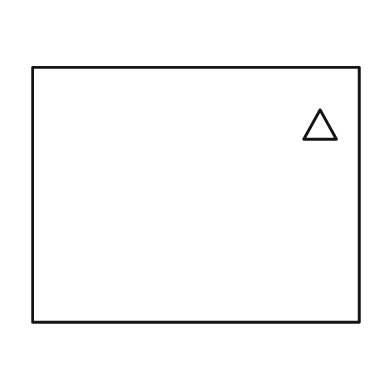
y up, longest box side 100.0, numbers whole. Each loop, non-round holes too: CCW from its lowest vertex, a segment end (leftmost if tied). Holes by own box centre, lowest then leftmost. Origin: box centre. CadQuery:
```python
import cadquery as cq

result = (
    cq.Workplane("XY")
    .moveTo(-50.0, -39.0)
    .lineTo(50.0, -39.0)
    .lineTo(50.0, 39.0)
    .lineTo(-50.0, 39.0)
    .close()
    .moveTo(33.0, 17.0)
    .lineTo(43.0, 17.0)
    .lineTo(38.0, 26.0)
    .close()
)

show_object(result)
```